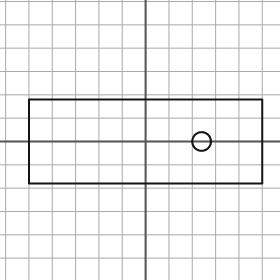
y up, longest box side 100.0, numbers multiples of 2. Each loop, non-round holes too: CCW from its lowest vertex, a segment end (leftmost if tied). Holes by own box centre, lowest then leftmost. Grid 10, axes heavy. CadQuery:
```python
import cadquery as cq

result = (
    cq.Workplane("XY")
    .moveTo(-50.0, -18.0)
    .lineTo(50.0, -18.0)
    .lineTo(50.0, 18.0)
    .lineTo(-50.0, 18.0)
    .close()
    .moveTo(24.0, 0.0)
    .circle(4.0)
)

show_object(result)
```